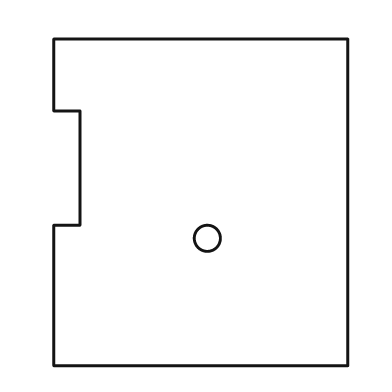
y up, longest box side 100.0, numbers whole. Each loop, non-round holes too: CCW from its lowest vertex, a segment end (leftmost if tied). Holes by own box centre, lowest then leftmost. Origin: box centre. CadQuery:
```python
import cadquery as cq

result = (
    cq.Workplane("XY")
    .moveTo(-45.0, -50.0)
    .lineTo(45.0, -50.0)
    .lineTo(45.0, 50.0)
    .lineTo(-45.0, 50.0)
    .lineTo(-45.0, 28.0)
    .lineTo(-37.0, 28.0)
    .lineTo(-37.0, -7.0)
    .lineTo(-45.0, -7.0)
    .close()
    .moveTo(2.0, -11.0)
    .circle(4.0)
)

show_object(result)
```